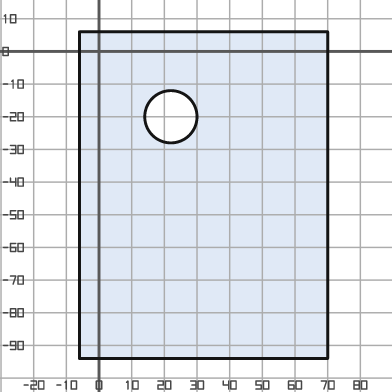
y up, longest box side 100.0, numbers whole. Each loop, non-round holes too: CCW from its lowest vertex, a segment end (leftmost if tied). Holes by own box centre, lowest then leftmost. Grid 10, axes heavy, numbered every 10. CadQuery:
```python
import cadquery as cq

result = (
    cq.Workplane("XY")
    .moveTo(-6.0, -94.0)
    .lineTo(70.0, -94.0)
    .lineTo(70.0, 6.0)
    .lineTo(-6.0, 6.0)
    .close()
    .moveTo(22.0, -20.0)
    .circle(8.0)
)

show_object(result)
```